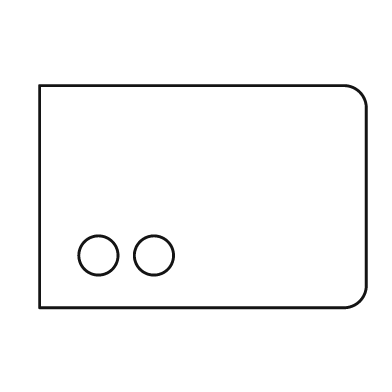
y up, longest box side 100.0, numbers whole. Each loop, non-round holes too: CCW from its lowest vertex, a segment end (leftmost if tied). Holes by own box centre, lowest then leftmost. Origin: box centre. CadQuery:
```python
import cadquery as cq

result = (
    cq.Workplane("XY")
    .moveTo(-50.0, -34.0)
    .lineTo(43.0, -34.0)
    .threePointArc((48.0, -32.0), (50.0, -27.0))
    .lineTo(50.0, 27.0)
    .threePointArc((48.0, 32.0), (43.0, 34.0))
    .lineTo(-50.0, 34.0)
    .close()
    .moveTo(-32.0, -18.0)
    .circle(6.0)
    .moveTo(-15.0, -18.0)
    .circle(6.0)
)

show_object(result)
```